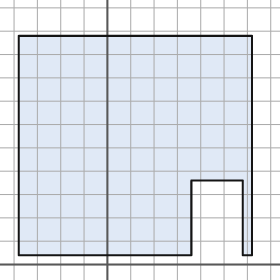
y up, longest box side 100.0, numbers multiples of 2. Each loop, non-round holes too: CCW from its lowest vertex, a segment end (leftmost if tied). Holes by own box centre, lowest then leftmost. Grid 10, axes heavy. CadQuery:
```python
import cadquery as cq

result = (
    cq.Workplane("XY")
    .moveTo(-38.0, 4.0)
    .lineTo(36.0, 4.0)
    .lineTo(36.0, 36.0)
    .lineTo(58.0, 36.0)
    .lineTo(58.0, 4.0)
    .lineTo(62.0, 4.0)
    .lineTo(62.0, 98.0)
    .lineTo(-38.0, 98.0)
    .close()
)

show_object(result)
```